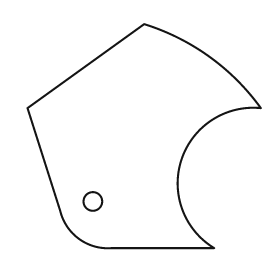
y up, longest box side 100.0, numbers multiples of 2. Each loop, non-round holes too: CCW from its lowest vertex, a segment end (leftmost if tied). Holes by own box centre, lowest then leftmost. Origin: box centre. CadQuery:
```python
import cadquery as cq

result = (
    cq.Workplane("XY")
    .moveTo(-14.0, -48.0)
    .lineTo(30.0, -48.0)
    .threePointArc((16.0, -10.0), (50.0, 12.0))
    .threePointArc((28.0, 34.0), (0.0, 48.0))
    .lineTo(-50.0, 12.0)
    .lineTo(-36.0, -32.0)
    .threePointArc((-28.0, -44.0), (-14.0, -48.0))
    .close()
    .moveTo(-22.0, -28.0)
    .circle(4.0)
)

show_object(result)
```